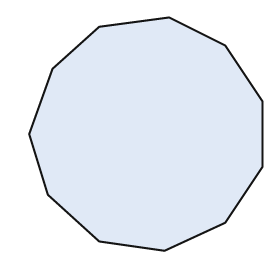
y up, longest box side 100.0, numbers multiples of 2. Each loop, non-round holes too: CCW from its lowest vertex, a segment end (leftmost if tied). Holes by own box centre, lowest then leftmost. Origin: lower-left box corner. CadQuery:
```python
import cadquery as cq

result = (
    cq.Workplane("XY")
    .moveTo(58.0, 0.0)
    .lineTo(84.0, 12.0)
    .lineTo(100.0, 36.0)
    .lineTo(100.0, 64.0)
    .lineTo(84.0, 88.0)
    .lineTo(60.0, 100.0)
    .lineTo(30.0, 96.0)
    .lineTo(10.0, 78.0)
    .lineTo(0.0, 50.0)
    .lineTo(8.0, 24.0)
    .lineTo(30.0, 4.0)
    .close()
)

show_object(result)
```